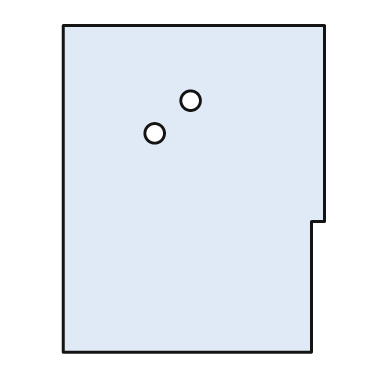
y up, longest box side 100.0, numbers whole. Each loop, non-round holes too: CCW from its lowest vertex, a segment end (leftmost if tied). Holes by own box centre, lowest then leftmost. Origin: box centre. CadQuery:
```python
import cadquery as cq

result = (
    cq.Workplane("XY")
    .moveTo(-40.0, -50.0)
    .lineTo(36.0, -50.0)
    .lineTo(36.0, -10.0)
    .lineTo(40.0, -10.0)
    .lineTo(40.0, 50.0)
    .lineTo(-40.0, 50.0)
    .close()
    .moveTo(-12.0, 17.0)
    .circle(3.0)
    .moveTo(-1.0, 27.0)
    .circle(3.0)
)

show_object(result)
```